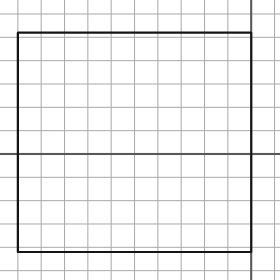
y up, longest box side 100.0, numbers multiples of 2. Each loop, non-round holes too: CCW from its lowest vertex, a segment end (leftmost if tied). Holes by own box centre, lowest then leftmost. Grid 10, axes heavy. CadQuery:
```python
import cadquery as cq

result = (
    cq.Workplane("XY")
    .moveTo(-100.0, -42.0)
    .lineTo(0.0, -42.0)
    .lineTo(0.0, 52.0)
    .lineTo(-100.0, 52.0)
    .close()
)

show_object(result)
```